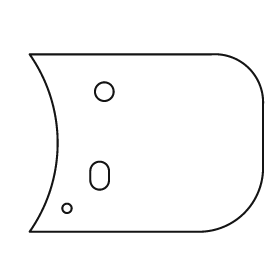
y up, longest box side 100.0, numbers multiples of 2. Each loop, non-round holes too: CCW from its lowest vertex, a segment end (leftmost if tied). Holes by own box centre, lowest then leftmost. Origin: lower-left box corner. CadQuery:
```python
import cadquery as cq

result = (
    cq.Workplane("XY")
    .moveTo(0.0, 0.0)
    .lineTo(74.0, 0.0)
    .threePointArc((92.0, 8.0), (100.0, 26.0))
    .lineTo(100.0, 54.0)
    .threePointArc((94.0, 70.0), (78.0, 76.0))
    .lineTo(0.0, 76.0)
    .threePointArc((12.0, 38.0), (0.0, 0.0))
    .close()
    .moveTo(16.0, 10.0)
    .circle(2.0)
    .moveTo(26.0, 22.0)
    .threePointArc((30.0, 18.0), (34.0, 22.0))
    .lineTo(34.0, 26.0)
    .threePointArc((30.0, 30.0), (26.0, 26.0))
    .close()
    .moveTo(32.0, 60.0)
    .circle(4.0)
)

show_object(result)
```